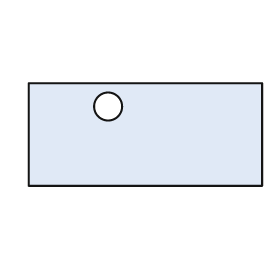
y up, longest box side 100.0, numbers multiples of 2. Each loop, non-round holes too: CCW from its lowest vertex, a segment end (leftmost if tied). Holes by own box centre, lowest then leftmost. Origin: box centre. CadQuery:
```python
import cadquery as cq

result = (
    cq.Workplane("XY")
    .moveTo(-50.0, -22.0)
    .lineTo(50.0, -22.0)
    .lineTo(50.0, 22.0)
    .lineTo(-50.0, 22.0)
    .close()
    .moveTo(-16.0, 12.0)
    .circle(6.0)
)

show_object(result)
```